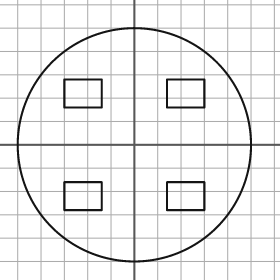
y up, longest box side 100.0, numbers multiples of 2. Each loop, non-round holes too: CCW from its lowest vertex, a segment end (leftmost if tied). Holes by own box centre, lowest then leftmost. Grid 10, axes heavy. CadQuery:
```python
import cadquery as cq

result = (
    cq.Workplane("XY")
    .moveTo(0.0, 0.0)
    .circle(50.0)
    .moveTo(-30.0, -28.0)
    .lineTo(-14.0, -28.0)
    .lineTo(-14.0, -16.0)
    .lineTo(-30.0, -16.0)
    .close()
    .moveTo(14.0, -28.0)
    .lineTo(30.0, -28.0)
    .lineTo(30.0, -16.0)
    .lineTo(14.0, -16.0)
    .close()
    .moveTo(-30.0, 16.0)
    .lineTo(-14.0, 16.0)
    .lineTo(-14.0, 28.0)
    .lineTo(-30.0, 28.0)
    .close()
    .moveTo(14.0, 16.0)
    .lineTo(30.0, 16.0)
    .lineTo(30.0, 28.0)
    .lineTo(14.0, 28.0)
    .close()
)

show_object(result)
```